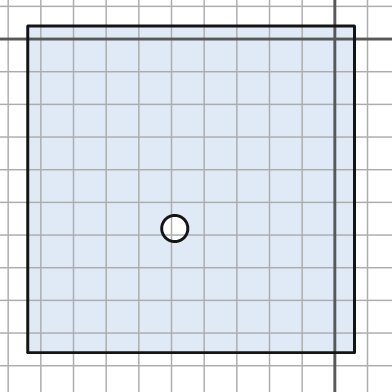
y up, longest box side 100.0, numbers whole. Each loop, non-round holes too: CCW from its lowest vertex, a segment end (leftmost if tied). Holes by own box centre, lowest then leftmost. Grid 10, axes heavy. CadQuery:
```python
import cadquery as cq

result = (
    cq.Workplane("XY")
    .moveTo(-94.0, -96.0)
    .lineTo(6.0, -96.0)
    .lineTo(6.0, 4.0)
    .lineTo(-94.0, 4.0)
    .close()
    .moveTo(-49.0, -58.0)
    .circle(4.0)
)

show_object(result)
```